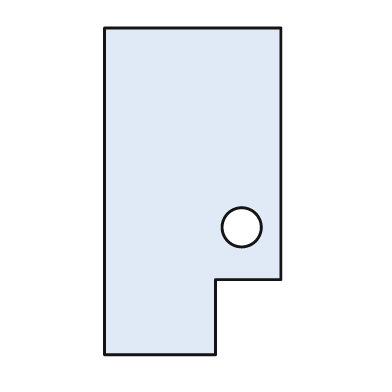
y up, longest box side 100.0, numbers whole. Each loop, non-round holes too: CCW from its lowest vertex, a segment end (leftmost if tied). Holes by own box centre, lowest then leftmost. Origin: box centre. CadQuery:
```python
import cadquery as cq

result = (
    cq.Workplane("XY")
    .moveTo(-27.0, -50.0)
    .lineTo(7.0, -50.0)
    .lineTo(7.0, -27.0)
    .lineTo(27.0, -27.0)
    .lineTo(27.0, 50.0)
    .lineTo(-27.0, 50.0)
    .close()
    .moveTo(15.0, -11.0)
    .circle(6.0)
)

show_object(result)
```